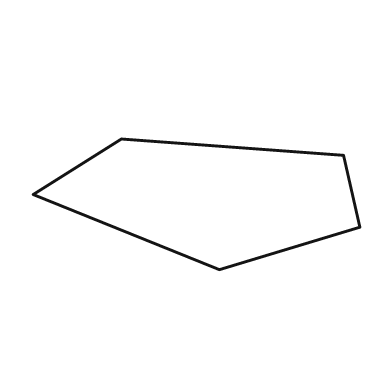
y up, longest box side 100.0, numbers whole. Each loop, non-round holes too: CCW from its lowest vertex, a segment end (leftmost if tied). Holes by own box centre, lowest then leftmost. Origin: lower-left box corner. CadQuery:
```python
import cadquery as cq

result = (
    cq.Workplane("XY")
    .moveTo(57.0, 0.0)
    .lineTo(100.0, 13.0)
    .lineTo(95.0, 35.0)
    .lineTo(27.0, 40.0)
    .lineTo(0.0, 23.0)
    .close()
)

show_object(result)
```